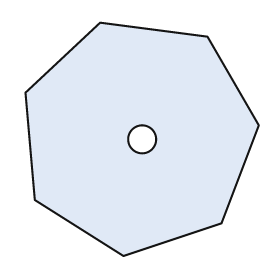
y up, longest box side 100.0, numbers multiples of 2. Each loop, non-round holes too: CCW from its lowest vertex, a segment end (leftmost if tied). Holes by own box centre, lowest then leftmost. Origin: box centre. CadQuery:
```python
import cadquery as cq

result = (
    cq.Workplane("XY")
    .moveTo(-8.0, -50.0)
    .lineTo(34.0, -36.0)
    .lineTo(50.0, 6.0)
    .lineTo(28.0, 44.0)
    .lineTo(-18.0, 50.0)
    .lineTo(-50.0, 20.0)
    .lineTo(-46.0, -26.0)
    .close()
    .moveTo(0.0, 0.0)
    .circle(6.0)
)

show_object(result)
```